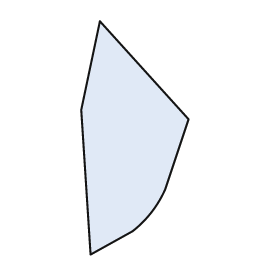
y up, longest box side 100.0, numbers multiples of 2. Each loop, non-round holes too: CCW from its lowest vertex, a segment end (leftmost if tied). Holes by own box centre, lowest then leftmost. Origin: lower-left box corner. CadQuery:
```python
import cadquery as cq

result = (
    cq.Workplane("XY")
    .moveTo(4.0, 0.0)
    .lineTo(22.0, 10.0)
    .threePointArc((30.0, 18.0), (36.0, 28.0))
    .lineTo(46.0, 58.0)
    .lineTo(8.0, 100.0)
    .lineTo(0.0, 62.0)
    .close()
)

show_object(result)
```